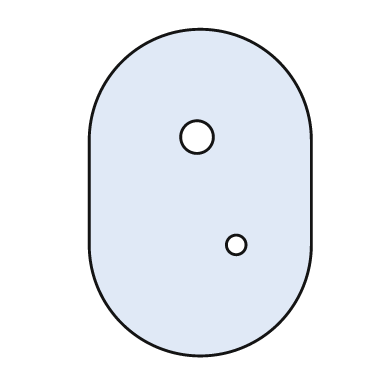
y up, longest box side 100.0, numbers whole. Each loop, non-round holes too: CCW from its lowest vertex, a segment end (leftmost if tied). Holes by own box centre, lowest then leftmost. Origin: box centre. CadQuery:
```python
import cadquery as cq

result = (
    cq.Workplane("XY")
    .moveTo(-34.0, -16.0)
    .threePointArc((0.0, -50.0), (34.0, -16.0))
    .lineTo(34.0, 16.0)
    .threePointArc((0.0, 50.0), (-34.0, 16.0))
    .close()
    .moveTo(11.0, -16.0)
    .circle(3.0)
    .moveTo(-1.0, 17.0)
    .circle(5.0)
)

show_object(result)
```